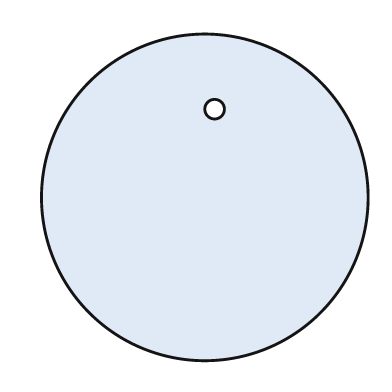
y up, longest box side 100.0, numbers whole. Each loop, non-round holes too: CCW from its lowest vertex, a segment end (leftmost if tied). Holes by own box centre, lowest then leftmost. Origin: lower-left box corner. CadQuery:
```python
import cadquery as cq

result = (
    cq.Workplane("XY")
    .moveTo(50.0, 50.0)
    .circle(50.0)
    .moveTo(53.0, 77.0)
    .circle(3.0)
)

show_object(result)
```